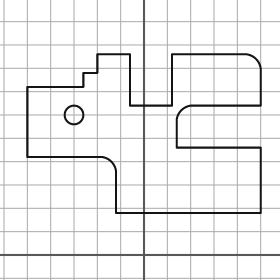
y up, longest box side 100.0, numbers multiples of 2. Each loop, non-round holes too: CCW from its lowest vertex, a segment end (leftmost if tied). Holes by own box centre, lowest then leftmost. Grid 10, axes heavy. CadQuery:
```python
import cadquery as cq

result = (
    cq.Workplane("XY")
    .moveTo(-12.0, 18.0)
    .lineTo(50.0, 18.0)
    .lineTo(50.0, 46.0)
    .lineTo(14.0, 46.0)
    .lineTo(14.0, 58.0)
    .threePointArc((16.0, 62.0), (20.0, 64.0))
    .lineTo(50.0, 64.0)
    .lineTo(50.0, 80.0)
    .threePointArc((48.0, 84.0), (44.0, 86.0))
    .lineTo(12.0, 86.0)
    .lineTo(12.0, 64.0)
    .lineTo(-6.0, 64.0)
    .lineTo(-6.0, 86.0)
    .lineTo(-20.0, 86.0)
    .lineTo(-20.0, 78.0)
    .lineTo(-26.0, 78.0)
    .lineTo(-26.0, 72.0)
    .lineTo(-50.0, 72.0)
    .lineTo(-50.0, 42.0)
    .lineTo(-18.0, 42.0)
    .threePointArc((-14.0, 40.0), (-12.0, 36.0))
    .close()
    .moveTo(-30.0, 60.0)
    .circle(4.0)
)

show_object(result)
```